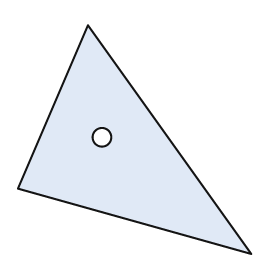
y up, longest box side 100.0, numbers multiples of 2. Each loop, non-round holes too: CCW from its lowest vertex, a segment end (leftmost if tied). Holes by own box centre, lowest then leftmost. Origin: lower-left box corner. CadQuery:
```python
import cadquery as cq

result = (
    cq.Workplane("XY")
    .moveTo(100.0, 0.0)
    .lineTo(30.0, 98.0)
    .lineTo(0.0, 28.0)
    .close()
    .moveTo(36.0, 50.0)
    .circle(4.0)
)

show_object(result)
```